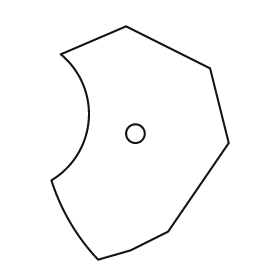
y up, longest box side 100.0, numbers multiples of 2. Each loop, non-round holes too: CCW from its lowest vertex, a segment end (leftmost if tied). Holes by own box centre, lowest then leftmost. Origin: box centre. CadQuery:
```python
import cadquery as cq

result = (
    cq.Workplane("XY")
    .moveTo(-18.0, -50.0)
    .lineTo(-4.0, -46.0)
    .lineTo(12.0, -38.0)
    .lineTo(38.0, 0.0)
    .lineTo(30.0, 32.0)
    .lineTo(-6.0, 50.0)
    .lineTo(-34.0, 38.0)
    .threePointArc((-22.0, 10.0), (-38.0, -16.0))
    .threePointArc((-30.0, -34.0), (-18.0, -50.0))
    .close()
    .moveTo(-2.0, 4.0)
    .circle(4.0)
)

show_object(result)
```